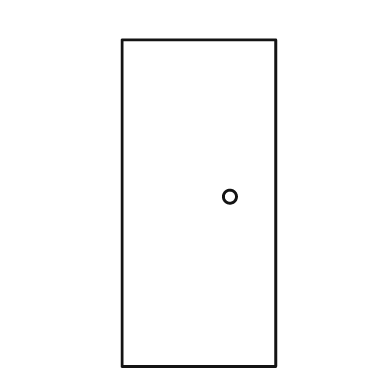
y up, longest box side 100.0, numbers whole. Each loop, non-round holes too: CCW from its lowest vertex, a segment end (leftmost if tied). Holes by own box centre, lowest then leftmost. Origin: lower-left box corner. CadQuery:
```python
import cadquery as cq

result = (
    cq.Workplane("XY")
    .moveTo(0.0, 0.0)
    .lineTo(47.0, 0.0)
    .lineTo(47.0, 100.0)
    .lineTo(0.0, 100.0)
    .close()
    .moveTo(33.0, 52.0)
    .circle(2.0)
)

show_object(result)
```